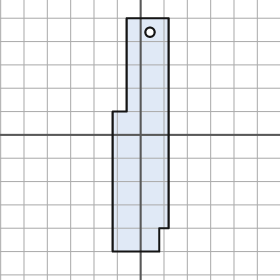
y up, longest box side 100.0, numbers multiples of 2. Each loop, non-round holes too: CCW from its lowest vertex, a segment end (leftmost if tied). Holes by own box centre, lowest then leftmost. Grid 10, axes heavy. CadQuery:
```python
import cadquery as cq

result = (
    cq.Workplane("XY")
    .moveTo(-12.0, -50.0)
    .lineTo(8.0, -50.0)
    .lineTo(8.0, -40.0)
    .lineTo(12.0, -40.0)
    .lineTo(12.0, 50.0)
    .lineTo(-6.0, 50.0)
    .lineTo(-6.0, 10.0)
    .lineTo(-12.0, 10.0)
    .close()
    .moveTo(4.0, 44.0)
    .circle(2.0)
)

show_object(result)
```